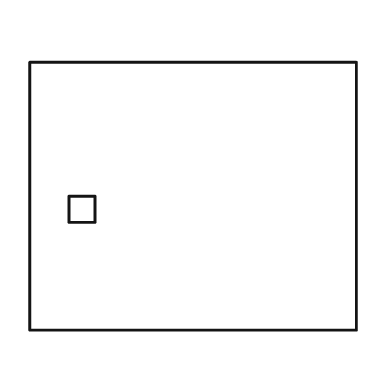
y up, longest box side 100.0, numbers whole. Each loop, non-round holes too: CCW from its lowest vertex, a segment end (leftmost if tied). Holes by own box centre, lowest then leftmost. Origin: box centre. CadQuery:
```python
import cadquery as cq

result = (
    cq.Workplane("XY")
    .moveTo(-50.0, -41.0)
    .lineTo(50.0, -41.0)
    .lineTo(50.0, 41.0)
    .lineTo(-50.0, 41.0)
    .close()
    .moveTo(-38.0, -8.0)
    .lineTo(-30.0, -8.0)
    .lineTo(-30.0, 0.0)
    .lineTo(-38.0, 0.0)
    .close()
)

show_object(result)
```